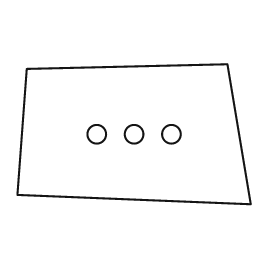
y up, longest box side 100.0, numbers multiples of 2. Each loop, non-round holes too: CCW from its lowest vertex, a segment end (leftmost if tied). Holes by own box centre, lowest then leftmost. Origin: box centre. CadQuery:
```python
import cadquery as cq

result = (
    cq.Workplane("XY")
    .moveTo(50.0, -30.0)
    .lineTo(40.0, 30.0)
    .lineTo(-46.0, 28.0)
    .lineTo(-50.0, -26.0)
    .close()
    .moveTo(-16.0, 0.0)
    .circle(4.0)
    .moveTo(0.0, 0.0)
    .circle(4.0)
    .moveTo(16.0, 0.0)
    .circle(4.0)
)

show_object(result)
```